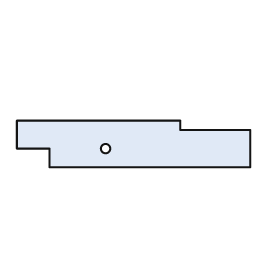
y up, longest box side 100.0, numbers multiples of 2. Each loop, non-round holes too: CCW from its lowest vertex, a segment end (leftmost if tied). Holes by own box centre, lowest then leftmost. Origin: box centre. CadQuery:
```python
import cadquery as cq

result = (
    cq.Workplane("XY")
    .moveTo(-36.0, -10.0)
    .lineTo(50.0, -10.0)
    .lineTo(50.0, 6.0)
    .lineTo(20.0, 6.0)
    .lineTo(20.0, 10.0)
    .lineTo(-50.0, 10.0)
    .lineTo(-50.0, -2.0)
    .lineTo(-36.0, -2.0)
    .close()
    .moveTo(-12.0, -2.0)
    .circle(2.0)
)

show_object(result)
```